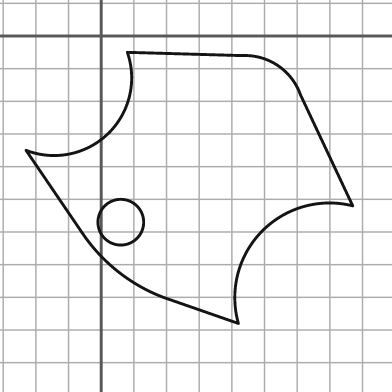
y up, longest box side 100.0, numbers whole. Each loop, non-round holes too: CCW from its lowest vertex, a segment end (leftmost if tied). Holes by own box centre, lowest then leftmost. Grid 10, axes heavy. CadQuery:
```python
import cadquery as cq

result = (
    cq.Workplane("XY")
    .moveTo(42.0, -88.0)
    .threePointArc((49.0, -60.0), (77.0, -52.0))
    .lineTo(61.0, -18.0)
    .threePointArc((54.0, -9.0), (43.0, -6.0))
    .lineTo(8.0, -5.0)
    .threePointArc((2.0, -30.0), (-23.0, -35.0))
    .lineTo(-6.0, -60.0)
    .threePointArc((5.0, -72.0), (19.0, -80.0))
    .close()
    .moveTo(6.0, -57.0)
    .circle(7.0)
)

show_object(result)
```